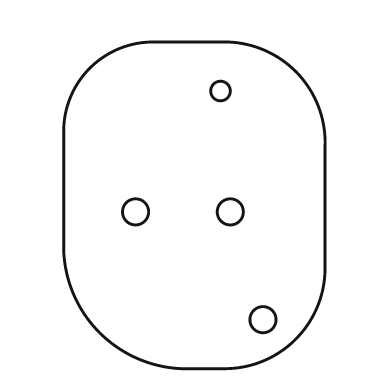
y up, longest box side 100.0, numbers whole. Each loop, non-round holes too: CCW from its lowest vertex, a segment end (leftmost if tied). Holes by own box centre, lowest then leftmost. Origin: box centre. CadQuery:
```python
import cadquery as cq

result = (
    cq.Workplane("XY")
    .moveTo(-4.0, -50.0)
    .lineTo(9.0, -50.0)
    .threePointArc((31.0, -41.0), (40.0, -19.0))
    .lineTo(40.0, 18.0)
    .threePointArc((31.0, 41.0), (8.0, 50.0))
    .lineTo(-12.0, 50.0)
    .threePointArc((-32.0, 42.0), (-40.0, 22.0))
    .lineTo(-40.0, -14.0)
    .threePointArc((-29.0, -39.0), (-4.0, -50.0))
    .close()
    .moveTo(21.0, -35.0)
    .circle(4.0)
    .moveTo(-18.0, -2.0)
    .circle(4.0)
    .moveTo(11.0, -2.0)
    .circle(4.0)
    .moveTo(8.0, 35.0)
    .circle(3.0)
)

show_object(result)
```